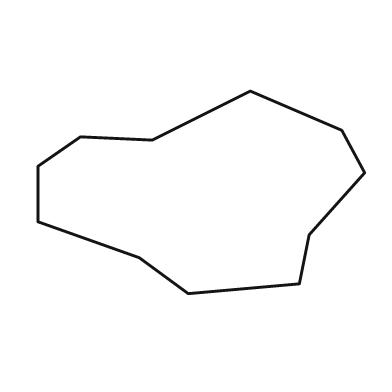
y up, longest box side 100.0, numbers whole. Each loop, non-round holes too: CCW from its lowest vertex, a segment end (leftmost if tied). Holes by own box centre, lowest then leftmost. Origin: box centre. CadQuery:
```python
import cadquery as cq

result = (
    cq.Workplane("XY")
    .moveTo(-4.0, -31.0)
    .lineTo(30.0, -28.0)
    .lineTo(33.0, -13.0)
    .lineTo(50.0, 6.0)
    .lineTo(43.0, 19.0)
    .lineTo(15.0, 31.0)
    .lineTo(-15.0, 16.0)
    .lineTo(-37.0, 17.0)
    .lineTo(-50.0, 8.0)
    .lineTo(-50.0, -9.0)
    .lineTo(-19.0, -20.0)
    .close()
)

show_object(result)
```